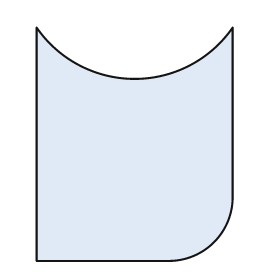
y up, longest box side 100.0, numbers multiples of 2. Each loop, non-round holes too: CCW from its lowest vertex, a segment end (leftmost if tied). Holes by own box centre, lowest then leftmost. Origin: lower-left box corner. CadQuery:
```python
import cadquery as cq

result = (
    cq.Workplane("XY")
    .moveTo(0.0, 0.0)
    .lineTo(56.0, 0.0)
    .threePointArc((76.0, 8.0), (84.0, 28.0))
    .lineTo(84.0, 100.0)
    .threePointArc((42.0, 78.0), (0.0, 100.0))
    .close()
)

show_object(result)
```